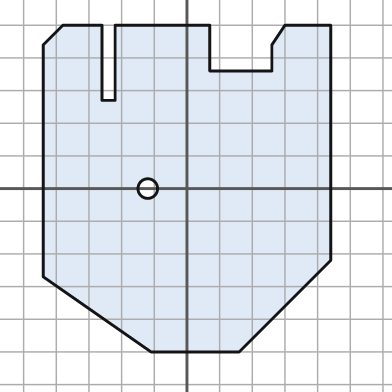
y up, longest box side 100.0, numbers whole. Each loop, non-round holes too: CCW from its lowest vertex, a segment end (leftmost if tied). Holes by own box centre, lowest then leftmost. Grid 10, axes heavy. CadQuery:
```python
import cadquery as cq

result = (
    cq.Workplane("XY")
    .moveTo(-11.0, -50.0)
    .lineTo(16.0, -50.0)
    .lineTo(44.0, -22.0)
    .lineTo(44.0, 50.0)
    .lineTo(30.0, 50.0)
    .lineTo(26.0, 44.0)
    .lineTo(26.0, 36.0)
    .lineTo(7.0, 36.0)
    .lineTo(7.0, 50.0)
    .lineTo(-22.0, 50.0)
    .lineTo(-22.0, 27.0)
    .lineTo(-26.0, 27.0)
    .lineTo(-26.0, 50.0)
    .lineTo(-38.0, 50.0)
    .lineTo(-44.0, 44.0)
    .lineTo(-44.0, -27.0)
    .close()
    .moveTo(-12.0, 0.0)
    .circle(3.0)
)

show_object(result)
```